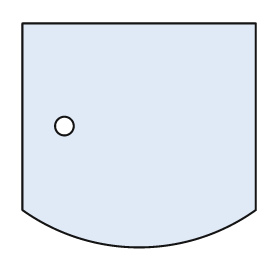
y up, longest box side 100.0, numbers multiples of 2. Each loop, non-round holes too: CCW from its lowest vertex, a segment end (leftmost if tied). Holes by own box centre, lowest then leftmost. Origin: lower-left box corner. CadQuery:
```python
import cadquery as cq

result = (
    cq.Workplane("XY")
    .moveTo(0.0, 16.0)
    .threePointArc((50.0, 0.0), (100.0, 16.0))
    .lineTo(100.0, 96.0)
    .lineTo(0.0, 96.0)
    .close()
    .moveTo(18.0, 52.0)
    .circle(4.0)
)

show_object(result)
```